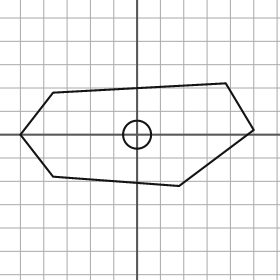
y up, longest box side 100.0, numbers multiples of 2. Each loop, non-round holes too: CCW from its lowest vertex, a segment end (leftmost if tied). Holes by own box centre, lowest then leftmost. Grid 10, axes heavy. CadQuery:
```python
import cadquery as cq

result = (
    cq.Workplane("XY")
    .moveTo(18.0, -22.0)
    .lineTo(50.0, 2.0)
    .lineTo(38.0, 22.0)
    .lineTo(-36.0, 18.0)
    .lineTo(-50.0, 0.0)
    .lineTo(-36.0, -18.0)
    .close()
    .moveTo(0.0, 0.0)
    .circle(6.0)
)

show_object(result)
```